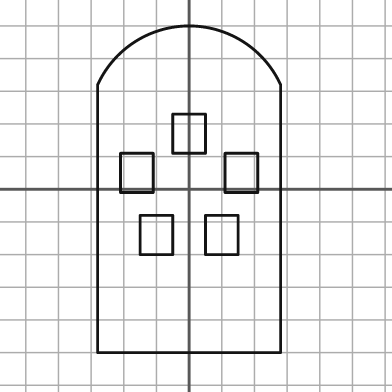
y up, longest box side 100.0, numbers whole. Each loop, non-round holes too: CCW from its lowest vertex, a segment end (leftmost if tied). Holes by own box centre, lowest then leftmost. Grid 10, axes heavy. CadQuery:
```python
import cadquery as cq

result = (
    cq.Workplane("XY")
    .moveTo(-28.0, -50.0)
    .lineTo(28.0, -50.0)
    .lineTo(28.0, 32.0)
    .threePointArc((0.0, 50.0), (-28.0, 32.0))
    .close()
    .moveTo(-15.0, -20.0)
    .lineTo(-5.0, -20.0)
    .lineTo(-5.0, -8.0)
    .lineTo(-15.0, -8.0)
    .close()
    .moveTo(5.0, -20.0)
    .lineTo(15.0, -20.0)
    .lineTo(15.0, -8.0)
    .lineTo(5.0, -8.0)
    .close()
    .moveTo(-21.0, -1.0)
    .lineTo(-11.0, -1.0)
    .lineTo(-11.0, 11.0)
    .lineTo(-21.0, 11.0)
    .close()
    .moveTo(11.0, -1.0)
    .lineTo(21.0, -1.0)
    .lineTo(21.0, 11.0)
    .lineTo(11.0, 11.0)
    .close()
    .moveTo(-5.0, 11.0)
    .lineTo(5.0, 11.0)
    .lineTo(5.0, 23.0)
    .lineTo(-5.0, 23.0)
    .close()
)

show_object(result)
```